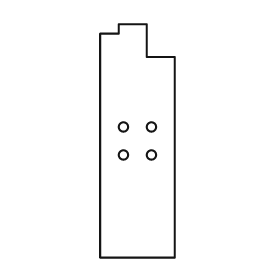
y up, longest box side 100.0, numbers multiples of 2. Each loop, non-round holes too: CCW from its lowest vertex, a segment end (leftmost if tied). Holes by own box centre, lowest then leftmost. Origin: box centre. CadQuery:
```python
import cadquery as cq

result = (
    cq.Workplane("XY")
    .moveTo(-16.0, -50.0)
    .lineTo(16.0, -50.0)
    .lineTo(16.0, 36.0)
    .lineTo(4.0, 36.0)
    .lineTo(4.0, 50.0)
    .lineTo(-8.0, 50.0)
    .lineTo(-8.0, 46.0)
    .lineTo(-16.0, 46.0)
    .close()
    .moveTo(-6.0, -6.0)
    .circle(2.0)
    .moveTo(6.0, -6.0)
    .circle(2.0)
    .moveTo(-6.0, 6.0)
    .circle(2.0)
    .moveTo(6.0, 6.0)
    .circle(2.0)
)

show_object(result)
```